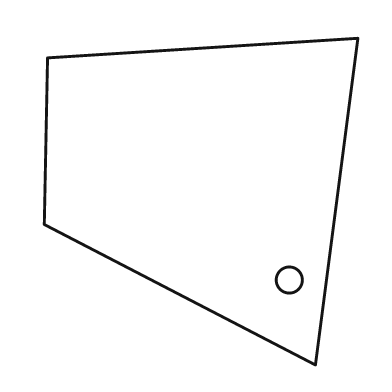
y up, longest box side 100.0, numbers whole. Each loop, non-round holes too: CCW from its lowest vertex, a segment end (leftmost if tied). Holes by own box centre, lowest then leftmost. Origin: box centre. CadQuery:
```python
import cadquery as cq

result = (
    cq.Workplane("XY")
    .moveTo(35.0, -50.0)
    .lineTo(48.0, 50.0)
    .lineTo(-47.0, 44.0)
    .lineTo(-48.0, -7.0)
    .close()
    .moveTo(27.0, -24.0)
    .circle(4.0)
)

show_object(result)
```